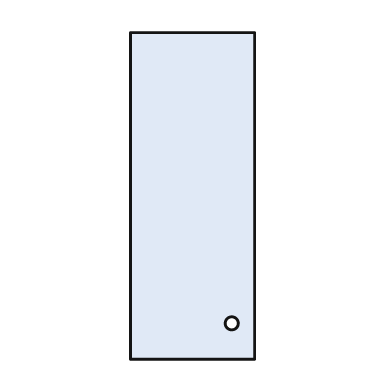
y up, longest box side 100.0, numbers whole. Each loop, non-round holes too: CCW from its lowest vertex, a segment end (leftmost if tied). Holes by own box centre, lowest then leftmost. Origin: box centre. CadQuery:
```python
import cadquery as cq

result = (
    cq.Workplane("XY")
    .moveTo(-19.0, -50.0)
    .lineTo(19.0, -50.0)
    .lineTo(19.0, 50.0)
    .lineTo(-19.0, 50.0)
    .close()
    .moveTo(12.0, -39.0)
    .circle(2.0)
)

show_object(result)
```